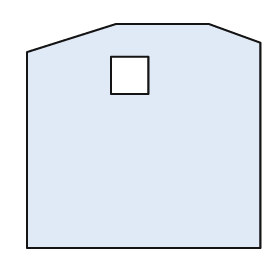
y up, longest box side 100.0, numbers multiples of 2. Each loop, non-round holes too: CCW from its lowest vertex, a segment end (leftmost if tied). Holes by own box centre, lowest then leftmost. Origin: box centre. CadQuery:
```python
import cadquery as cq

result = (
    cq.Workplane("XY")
    .moveTo(-50.0, -48.0)
    .lineTo(50.0, -48.0)
    .lineTo(50.0, 40.0)
    .lineTo(28.0, 48.0)
    .lineTo(-12.0, 48.0)
    .lineTo(-50.0, 36.0)
    .close()
    .moveTo(-14.0, 18.0)
    .lineTo(2.0, 18.0)
    .lineTo(2.0, 34.0)
    .lineTo(-14.0, 34.0)
    .close()
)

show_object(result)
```